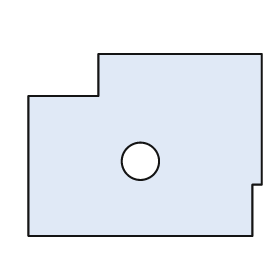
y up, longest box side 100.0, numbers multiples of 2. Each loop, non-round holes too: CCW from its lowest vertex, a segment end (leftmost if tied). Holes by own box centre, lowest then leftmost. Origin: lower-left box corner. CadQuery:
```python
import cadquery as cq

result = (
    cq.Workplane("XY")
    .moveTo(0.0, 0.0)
    .lineTo(96.0, 0.0)
    .lineTo(96.0, 22.0)
    .lineTo(100.0, 22.0)
    .lineTo(100.0, 78.0)
    .lineTo(30.0, 78.0)
    .lineTo(30.0, 60.0)
    .lineTo(0.0, 60.0)
    .close()
    .moveTo(48.0, 32.0)
    .circle(8.0)
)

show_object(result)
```